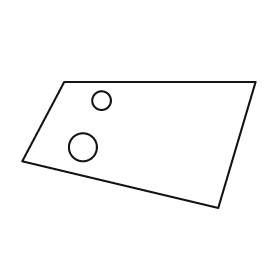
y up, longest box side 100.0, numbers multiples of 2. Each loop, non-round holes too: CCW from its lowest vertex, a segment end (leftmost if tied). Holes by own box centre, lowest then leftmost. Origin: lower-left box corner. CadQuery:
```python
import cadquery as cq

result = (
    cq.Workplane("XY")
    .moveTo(84.0, 0.0)
    .lineTo(100.0, 54.0)
    .lineTo(18.0, 54.0)
    .lineTo(0.0, 20.0)
    .close()
    .moveTo(26.0, 26.0)
    .circle(6.0)
    .moveTo(34.0, 46.0)
    .circle(4.0)
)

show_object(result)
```